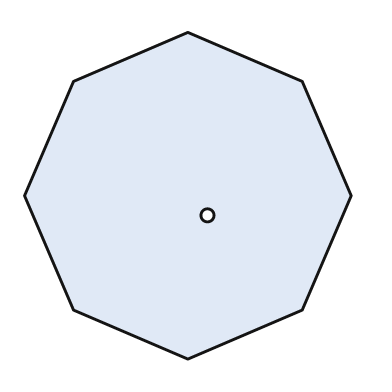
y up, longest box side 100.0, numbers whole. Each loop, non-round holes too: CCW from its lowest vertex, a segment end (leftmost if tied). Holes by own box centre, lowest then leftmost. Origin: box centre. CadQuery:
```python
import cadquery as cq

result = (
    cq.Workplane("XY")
    .moveTo(0.0, -50.0)
    .lineTo(35.0, -35.0)
    .lineTo(50.0, 0.0)
    .lineTo(35.0, 35.0)
    .lineTo(0.0, 50.0)
    .lineTo(-35.0, 35.0)
    .lineTo(-50.0, 0.0)
    .lineTo(-35.0, -35.0)
    .close()
    .moveTo(6.0, -6.0)
    .circle(2.0)
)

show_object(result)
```